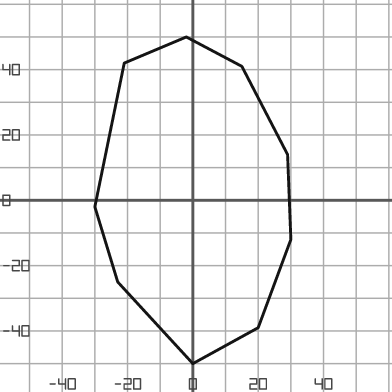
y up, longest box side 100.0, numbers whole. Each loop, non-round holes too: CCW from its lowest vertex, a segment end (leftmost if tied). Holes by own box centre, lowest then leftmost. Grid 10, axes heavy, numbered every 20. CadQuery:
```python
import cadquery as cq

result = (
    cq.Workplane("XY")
    .moveTo(0.0, -50.0)
    .lineTo(20.0, -39.0)
    .lineTo(30.0, -12.0)
    .lineTo(29.0, 14.0)
    .lineTo(15.0, 41.0)
    .lineTo(-2.0, 50.0)
    .lineTo(-21.0, 42.0)
    .lineTo(-30.0, -2.0)
    .lineTo(-23.0, -25.0)
    .close()
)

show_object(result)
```